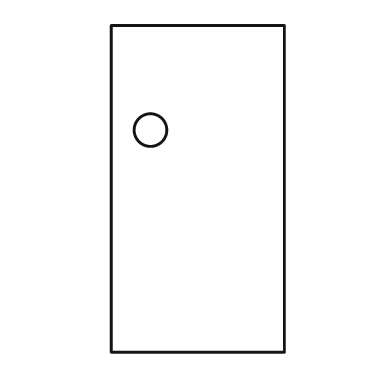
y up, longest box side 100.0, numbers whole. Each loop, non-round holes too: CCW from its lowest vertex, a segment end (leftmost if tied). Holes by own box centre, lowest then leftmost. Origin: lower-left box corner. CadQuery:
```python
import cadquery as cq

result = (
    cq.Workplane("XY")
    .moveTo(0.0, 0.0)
    .lineTo(53.0, 0.0)
    .lineTo(53.0, 100.0)
    .lineTo(0.0, 100.0)
    .close()
    .moveTo(12.0, 68.0)
    .circle(5.0)
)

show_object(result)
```